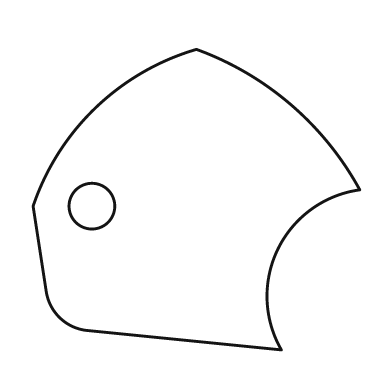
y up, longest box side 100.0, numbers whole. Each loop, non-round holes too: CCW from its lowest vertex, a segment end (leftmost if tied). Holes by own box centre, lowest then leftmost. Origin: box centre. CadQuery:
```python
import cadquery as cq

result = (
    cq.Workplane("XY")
    .moveTo(26.0, -46.0)
    .threePointArc((25.0, -15.0), (50.0, 3.0))
    .threePointArc((29.0, 29.0), (0.0, 46.0))
    .threePointArc((-31.0, 28.0), (-50.0, -2.0))
    .lineTo(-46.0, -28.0)
    .threePointArc((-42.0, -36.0), (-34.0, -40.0))
    .close()
    .moveTo(-32.0, -2.0)
    .circle(7.0)
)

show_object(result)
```